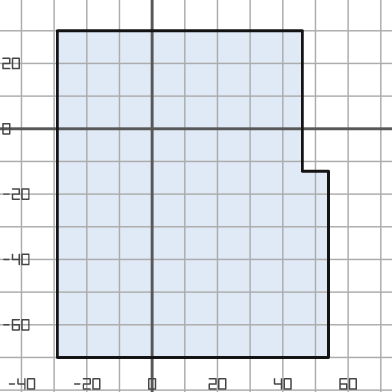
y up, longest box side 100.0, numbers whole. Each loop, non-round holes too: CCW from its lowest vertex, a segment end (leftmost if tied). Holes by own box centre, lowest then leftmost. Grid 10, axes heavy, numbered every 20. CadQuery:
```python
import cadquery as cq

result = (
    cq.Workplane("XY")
    .moveTo(-29.0, -70.0)
    .lineTo(54.0, -70.0)
    .lineTo(54.0, -13.0)
    .lineTo(46.0, -13.0)
    .lineTo(46.0, 30.0)
    .lineTo(-29.0, 30.0)
    .close()
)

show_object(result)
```